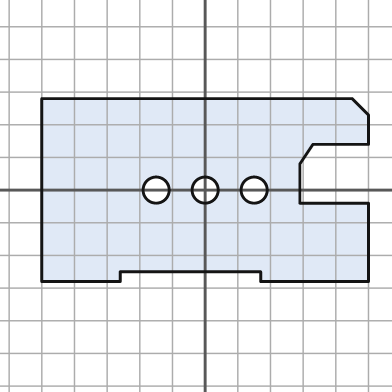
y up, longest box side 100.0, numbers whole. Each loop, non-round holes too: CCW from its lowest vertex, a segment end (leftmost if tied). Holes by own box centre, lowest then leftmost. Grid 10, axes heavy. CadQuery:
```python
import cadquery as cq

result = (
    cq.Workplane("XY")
    .moveTo(-50.0, -28.0)
    .lineTo(-26.0, -28.0)
    .lineTo(-26.0, -25.0)
    .lineTo(17.0, -25.0)
    .lineTo(17.0, -28.0)
    .lineTo(50.0, -28.0)
    .lineTo(50.0, -4.0)
    .lineTo(29.0, -4.0)
    .lineTo(29.0, 8.0)
    .lineTo(33.0, 14.0)
    .lineTo(50.0, 14.0)
    .lineTo(50.0, 23.0)
    .lineTo(45.0, 28.0)
    .lineTo(-50.0, 28.0)
    .close()
    .moveTo(-15.0, 0.0)
    .circle(4.0)
    .moveTo(0.0, 0.0)
    .circle(4.0)
    .moveTo(15.0, 0.0)
    .circle(4.0)
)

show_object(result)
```